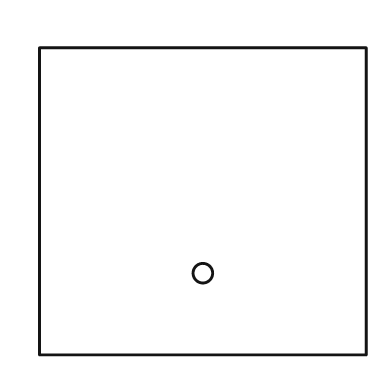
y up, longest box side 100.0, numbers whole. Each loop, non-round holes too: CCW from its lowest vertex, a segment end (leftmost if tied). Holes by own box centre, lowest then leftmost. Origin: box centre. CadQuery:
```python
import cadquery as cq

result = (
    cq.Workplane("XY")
    .moveTo(-50.0, -47.0)
    .lineTo(50.0, -47.0)
    .lineTo(50.0, 47.0)
    .lineTo(-50.0, 47.0)
    .close()
    .moveTo(0.0, -22.0)
    .circle(3.0)
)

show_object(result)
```